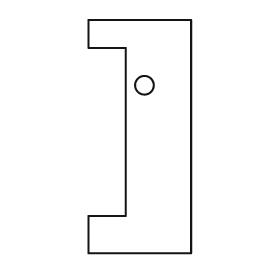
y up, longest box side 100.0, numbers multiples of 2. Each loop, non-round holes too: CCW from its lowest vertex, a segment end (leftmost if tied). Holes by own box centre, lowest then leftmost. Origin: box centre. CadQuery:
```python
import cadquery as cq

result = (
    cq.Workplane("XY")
    .moveTo(-22.0, -50.0)
    .lineTo(22.0, -50.0)
    .lineTo(22.0, 50.0)
    .lineTo(-22.0, 50.0)
    .lineTo(-22.0, 38.0)
    .lineTo(-6.0, 38.0)
    .lineTo(-6.0, -34.0)
    .lineTo(-22.0, -34.0)
    .close()
    .moveTo(2.0, 22.0)
    .circle(4.0)
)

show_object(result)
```